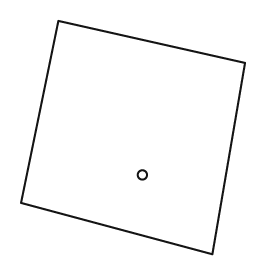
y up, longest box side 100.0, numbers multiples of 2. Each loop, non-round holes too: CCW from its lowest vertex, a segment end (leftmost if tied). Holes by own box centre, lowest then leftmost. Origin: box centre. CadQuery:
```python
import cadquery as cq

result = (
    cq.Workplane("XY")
    .moveTo(34.0, -50.0)
    .lineTo(48.0, 32.0)
    .lineTo(-32.0, 50.0)
    .lineTo(-48.0, -28.0)
    .close()
    .moveTo(4.0, -16.0)
    .circle(2.0)
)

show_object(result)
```